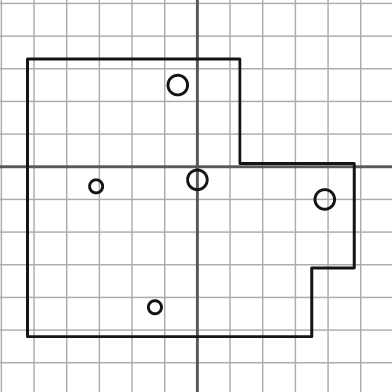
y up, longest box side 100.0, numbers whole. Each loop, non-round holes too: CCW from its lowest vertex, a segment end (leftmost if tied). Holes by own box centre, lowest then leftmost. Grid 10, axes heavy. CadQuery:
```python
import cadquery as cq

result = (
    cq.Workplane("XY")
    .moveTo(-52.0, -52.0)
    .lineTo(35.0, -52.0)
    .lineTo(35.0, -31.0)
    .lineTo(48.0, -31.0)
    .lineTo(48.0, 1.0)
    .lineTo(13.0, 1.0)
    .lineTo(13.0, 33.0)
    .lineTo(-52.0, 33.0)
    .close()
    .moveTo(-13.0, -43.0)
    .circle(2.0)
    .moveTo(39.0, -10.0)
    .circle(3.0)
    .moveTo(-31.0, -6.0)
    .circle(2.0)
    .moveTo(0.0, -4.0)
    .circle(3.0)
    .moveTo(-6.0, 25.0)
    .circle(3.0)
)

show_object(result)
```